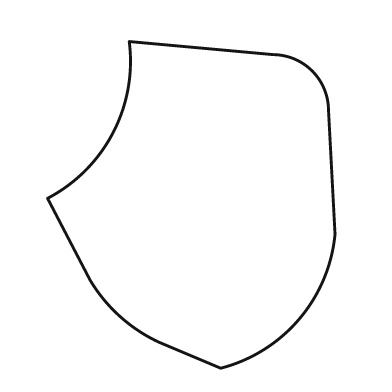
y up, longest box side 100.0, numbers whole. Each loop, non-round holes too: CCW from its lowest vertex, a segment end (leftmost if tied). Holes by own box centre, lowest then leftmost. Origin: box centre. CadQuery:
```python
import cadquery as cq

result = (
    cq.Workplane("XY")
    .moveTo(9.0, -50.0)
    .threePointArc((33.0, -35.0), (44.0, -9.0))
    .lineTo(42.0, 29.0)
    .threePointArc((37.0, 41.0), (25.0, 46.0))
    .lineTo(-19.0, 50.0)
    .threePointArc((-24.0, 22.0), (-44.0, 2.0))
    .lineTo(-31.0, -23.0)
    .threePointArc((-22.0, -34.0), (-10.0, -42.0))
    .close()
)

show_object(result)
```